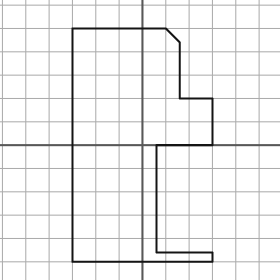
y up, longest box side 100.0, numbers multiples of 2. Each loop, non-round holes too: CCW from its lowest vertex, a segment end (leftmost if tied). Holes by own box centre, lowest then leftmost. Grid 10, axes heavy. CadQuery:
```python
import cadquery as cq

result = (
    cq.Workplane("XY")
    .moveTo(-30.0, -50.0)
    .lineTo(30.0, -50.0)
    .lineTo(30.0, -46.0)
    .lineTo(6.0, -46.0)
    .lineTo(6.0, 0.0)
    .lineTo(30.0, 0.0)
    .lineTo(30.0, 20.0)
    .lineTo(16.0, 20.0)
    .lineTo(16.0, 44.0)
    .lineTo(10.0, 50.0)
    .lineTo(-30.0, 50.0)
    .close()
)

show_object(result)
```